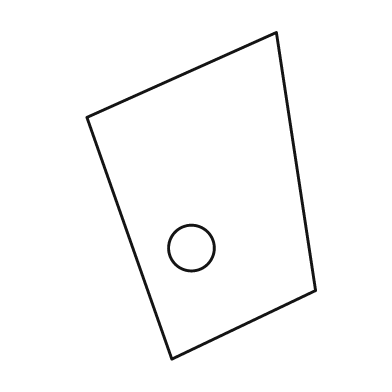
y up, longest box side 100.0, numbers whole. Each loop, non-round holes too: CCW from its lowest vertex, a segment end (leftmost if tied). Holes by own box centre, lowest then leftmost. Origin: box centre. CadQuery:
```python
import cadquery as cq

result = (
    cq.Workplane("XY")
    .moveTo(-9.0, -50.0)
    .lineTo(35.0, -29.0)
    .lineTo(23.0, 50.0)
    .lineTo(-35.0, 24.0)
    .close()
    .moveTo(-3.0, -16.0)
    .circle(7.0)
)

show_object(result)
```